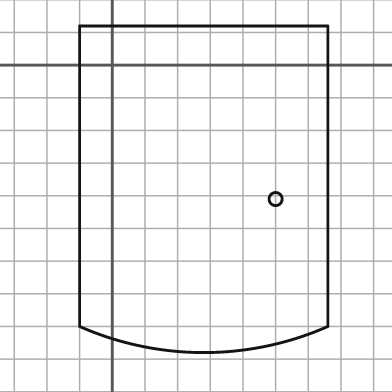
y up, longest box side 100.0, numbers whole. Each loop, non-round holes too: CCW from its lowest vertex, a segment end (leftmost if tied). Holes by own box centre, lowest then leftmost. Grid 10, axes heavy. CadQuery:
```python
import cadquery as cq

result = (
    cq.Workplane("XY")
    .moveTo(-10.0, -80.0)
    .threePointArc((28.0, -88.0), (66.0, -80.0))
    .lineTo(66.0, 12.0)
    .lineTo(-10.0, 12.0)
    .close()
    .moveTo(50.0, -41.0)
    .circle(2.0)
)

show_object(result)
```